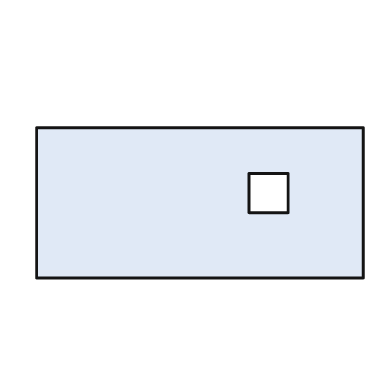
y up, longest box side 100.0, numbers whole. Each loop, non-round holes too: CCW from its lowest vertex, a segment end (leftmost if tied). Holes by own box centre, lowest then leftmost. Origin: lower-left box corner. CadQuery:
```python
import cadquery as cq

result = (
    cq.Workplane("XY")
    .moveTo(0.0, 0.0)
    .lineTo(100.0, 0.0)
    .lineTo(100.0, 46.0)
    .lineTo(0.0, 46.0)
    .close()
    .moveTo(65.0, 20.0)
    .lineTo(77.0, 20.0)
    .lineTo(77.0, 32.0)
    .lineTo(65.0, 32.0)
    .close()
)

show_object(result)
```